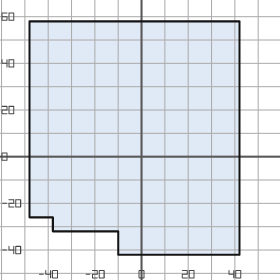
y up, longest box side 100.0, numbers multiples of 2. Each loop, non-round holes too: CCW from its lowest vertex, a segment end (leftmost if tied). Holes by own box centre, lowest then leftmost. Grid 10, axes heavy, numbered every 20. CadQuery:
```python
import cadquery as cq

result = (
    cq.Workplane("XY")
    .moveTo(-10.0, -42.0)
    .lineTo(42.0, -42.0)
    .lineTo(42.0, 58.0)
    .lineTo(-48.0, 58.0)
    .lineTo(-48.0, -26.0)
    .lineTo(-38.0, -26.0)
    .lineTo(-38.0, -32.0)
    .lineTo(-10.0, -32.0)
    .close()
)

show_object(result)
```